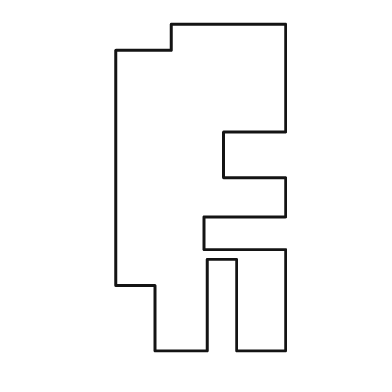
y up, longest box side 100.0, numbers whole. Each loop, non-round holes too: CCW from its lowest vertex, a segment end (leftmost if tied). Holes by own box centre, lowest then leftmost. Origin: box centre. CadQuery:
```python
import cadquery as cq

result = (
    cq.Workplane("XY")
    .moveTo(-14.0, -50.0)
    .lineTo(2.0, -50.0)
    .lineTo(2.0, -22.0)
    .lineTo(11.0, -22.0)
    .lineTo(11.0, -50.0)
    .lineTo(26.0, -50.0)
    .lineTo(26.0, -19.0)
    .lineTo(1.0, -19.0)
    .lineTo(1.0, -9.0)
    .lineTo(26.0, -9.0)
    .lineTo(26.0, 3.0)
    .lineTo(7.0, 3.0)
    .lineTo(7.0, 17.0)
    .lineTo(26.0, 17.0)
    .lineTo(26.0, 50.0)
    .lineTo(-9.0, 50.0)
    .lineTo(-9.0, 42.0)
    .lineTo(-26.0, 42.0)
    .lineTo(-26.0, -30.0)
    .lineTo(-14.0, -30.0)
    .close()
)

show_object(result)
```